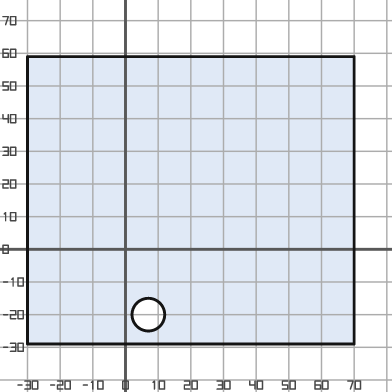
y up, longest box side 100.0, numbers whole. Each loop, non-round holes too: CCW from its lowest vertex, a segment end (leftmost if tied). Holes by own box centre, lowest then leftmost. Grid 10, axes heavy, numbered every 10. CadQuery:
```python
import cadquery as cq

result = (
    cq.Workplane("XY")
    .moveTo(-30.0, -29.0)
    .lineTo(70.0, -29.0)
    .lineTo(70.0, 59.0)
    .lineTo(-30.0, 59.0)
    .close()
    .moveTo(7.0, -20.0)
    .circle(5.0)
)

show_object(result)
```